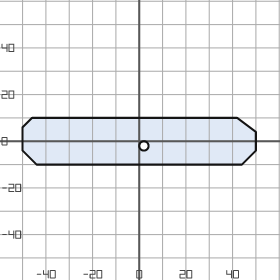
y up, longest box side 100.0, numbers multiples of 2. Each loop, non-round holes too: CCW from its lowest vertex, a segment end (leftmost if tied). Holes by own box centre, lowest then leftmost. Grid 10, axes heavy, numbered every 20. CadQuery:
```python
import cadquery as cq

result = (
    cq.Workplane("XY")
    .moveTo(-44.0, -10.0)
    .lineTo(44.0, -10.0)
    .lineTo(50.0, -4.0)
    .lineTo(50.0, 4.0)
    .lineTo(42.0, 10.0)
    .lineTo(-46.0, 10.0)
    .lineTo(-50.0, 6.0)
    .lineTo(-50.0, -4.0)
    .close()
    .moveTo(2.0, -2.0)
    .circle(2.0)
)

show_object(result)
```